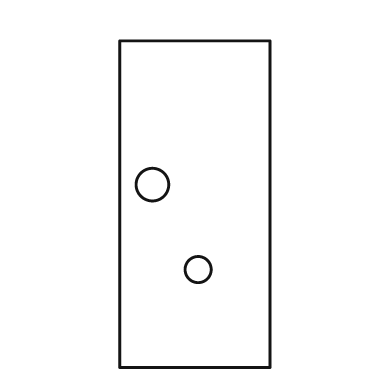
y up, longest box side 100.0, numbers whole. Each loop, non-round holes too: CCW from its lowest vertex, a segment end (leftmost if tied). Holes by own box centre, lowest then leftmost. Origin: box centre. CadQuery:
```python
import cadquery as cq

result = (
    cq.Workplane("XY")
    .moveTo(-23.0, -50.0)
    .lineTo(23.0, -50.0)
    .lineTo(23.0, 50.0)
    .lineTo(-23.0, 50.0)
    .close()
    .moveTo(1.0, -20.0)
    .circle(4.0)
    .moveTo(-13.0, 6.0)
    .circle(5.0)
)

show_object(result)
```